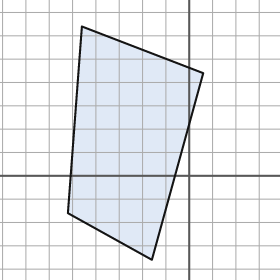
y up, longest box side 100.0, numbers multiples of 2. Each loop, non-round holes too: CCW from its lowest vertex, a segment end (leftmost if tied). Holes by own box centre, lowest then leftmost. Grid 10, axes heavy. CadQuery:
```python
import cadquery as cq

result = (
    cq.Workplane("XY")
    .moveTo(-16.0, -36.0)
    .lineTo(6.0, 44.0)
    .lineTo(-46.0, 64.0)
    .lineTo(-52.0, -16.0)
    .close()
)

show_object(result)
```